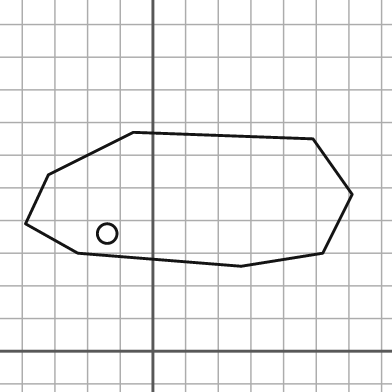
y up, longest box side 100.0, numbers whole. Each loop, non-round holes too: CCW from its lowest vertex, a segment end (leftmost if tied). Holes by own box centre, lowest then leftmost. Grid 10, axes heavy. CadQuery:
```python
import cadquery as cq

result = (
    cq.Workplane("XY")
    .moveTo(27.0, 26.0)
    .lineTo(52.0, 30.0)
    .lineTo(61.0, 48.0)
    .lineTo(49.0, 65.0)
    .lineTo(-6.0, 67.0)
    .lineTo(-32.0, 54.0)
    .lineTo(-39.0, 39.0)
    .lineTo(-23.0, 30.0)
    .close()
    .moveTo(-14.0, 36.0)
    .circle(3.0)
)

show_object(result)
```